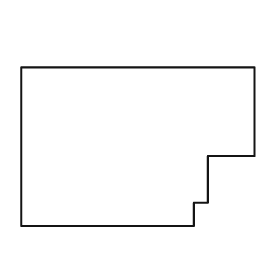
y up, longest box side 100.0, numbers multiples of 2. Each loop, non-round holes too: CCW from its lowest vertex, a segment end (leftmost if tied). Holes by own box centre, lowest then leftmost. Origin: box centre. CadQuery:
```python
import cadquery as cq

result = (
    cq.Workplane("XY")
    .moveTo(-50.0, -34.0)
    .lineTo(24.0, -34.0)
    .lineTo(24.0, -24.0)
    .lineTo(30.0, -24.0)
    .lineTo(30.0, -4.0)
    .lineTo(50.0, -4.0)
    .lineTo(50.0, 34.0)
    .lineTo(-50.0, 34.0)
    .close()
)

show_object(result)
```